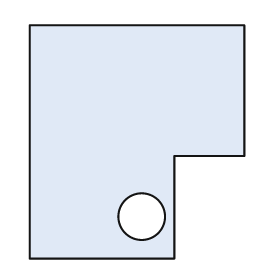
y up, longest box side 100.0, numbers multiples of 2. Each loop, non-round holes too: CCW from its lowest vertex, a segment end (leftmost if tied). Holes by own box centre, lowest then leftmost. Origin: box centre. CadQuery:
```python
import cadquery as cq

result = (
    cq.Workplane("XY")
    .moveTo(-46.0, -50.0)
    .lineTo(16.0, -50.0)
    .lineTo(16.0, -6.0)
    .lineTo(46.0, -6.0)
    .lineTo(46.0, 50.0)
    .lineTo(-46.0, 50.0)
    .close()
    .moveTo(2.0, -32.0)
    .circle(10.0)
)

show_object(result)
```